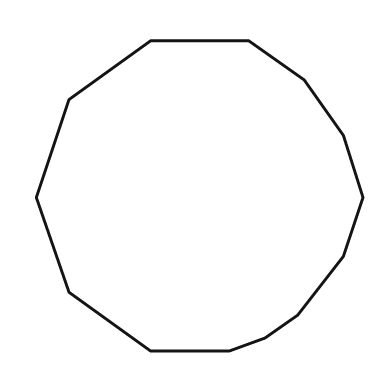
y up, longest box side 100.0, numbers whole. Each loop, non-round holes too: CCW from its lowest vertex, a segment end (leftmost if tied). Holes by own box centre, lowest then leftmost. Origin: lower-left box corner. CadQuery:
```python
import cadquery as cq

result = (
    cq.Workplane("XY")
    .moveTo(35.0, 0.0)
    .lineTo(59.0, 0.0)
    .lineTo(70.0, 4.0)
    .lineTo(80.0, 11.0)
    .lineTo(94.0, 29.0)
    .lineTo(100.0, 47.0)
    .lineTo(94.0, 66.0)
    .lineTo(82.0, 83.0)
    .lineTo(65.0, 95.0)
    .lineTo(35.0, 95.0)
    .lineTo(10.0, 77.0)
    .lineTo(0.0, 47.0)
    .lineTo(10.0, 18.0)
    .close()
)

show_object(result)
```